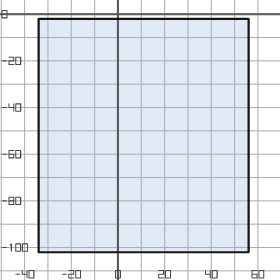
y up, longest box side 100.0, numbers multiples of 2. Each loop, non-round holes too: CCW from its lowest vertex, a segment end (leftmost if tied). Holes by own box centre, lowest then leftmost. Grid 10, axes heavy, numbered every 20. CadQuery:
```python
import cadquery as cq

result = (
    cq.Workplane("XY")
    .moveTo(-34.0, -102.0)
    .lineTo(56.0, -102.0)
    .lineTo(56.0, -2.0)
    .lineTo(-34.0, -2.0)
    .close()
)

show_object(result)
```